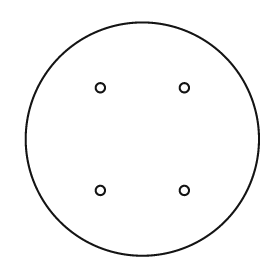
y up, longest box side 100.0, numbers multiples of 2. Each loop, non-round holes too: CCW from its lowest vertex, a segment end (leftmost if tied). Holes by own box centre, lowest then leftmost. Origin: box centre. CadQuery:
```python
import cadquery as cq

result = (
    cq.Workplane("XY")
    .moveTo(0.0, 0.0)
    .circle(50.0)
    .moveTo(-18.0, -22.0)
    .circle(2.0)
    .moveTo(18.0, -22.0)
    .circle(2.0)
    .moveTo(-18.0, 22.0)
    .circle(2.0)
    .moveTo(18.0, 22.0)
    .circle(2.0)
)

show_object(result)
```